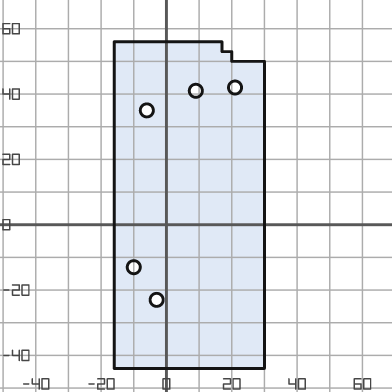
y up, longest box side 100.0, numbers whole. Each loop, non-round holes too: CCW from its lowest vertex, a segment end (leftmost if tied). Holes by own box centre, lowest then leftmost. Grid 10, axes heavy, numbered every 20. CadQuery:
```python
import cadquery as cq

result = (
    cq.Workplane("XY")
    .moveTo(-16.0, -44.0)
    .lineTo(30.0, -44.0)
    .lineTo(30.0, 50.0)
    .lineTo(20.0, 50.0)
    .lineTo(20.0, 53.0)
    .lineTo(17.0, 53.0)
    .lineTo(17.0, 56.0)
    .lineTo(-16.0, 56.0)
    .close()
    .moveTo(-3.0, -23.0)
    .circle(2.0)
    .moveTo(-10.0, -13.0)
    .circle(2.0)
    .moveTo(-6.0, 35.0)
    .circle(2.0)
    .moveTo(9.0, 41.0)
    .circle(2.0)
    .moveTo(21.0, 42.0)
    .circle(2.0)
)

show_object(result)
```